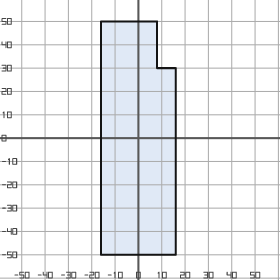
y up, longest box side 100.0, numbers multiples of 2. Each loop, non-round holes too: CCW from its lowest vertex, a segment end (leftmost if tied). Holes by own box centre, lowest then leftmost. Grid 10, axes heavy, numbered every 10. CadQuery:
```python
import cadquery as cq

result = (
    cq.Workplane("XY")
    .moveTo(-16.0, -50.0)
    .lineTo(16.0, -50.0)
    .lineTo(16.0, 30.0)
    .lineTo(8.0, 30.0)
    .lineTo(8.0, 50.0)
    .lineTo(-16.0, 50.0)
    .close()
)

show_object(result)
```